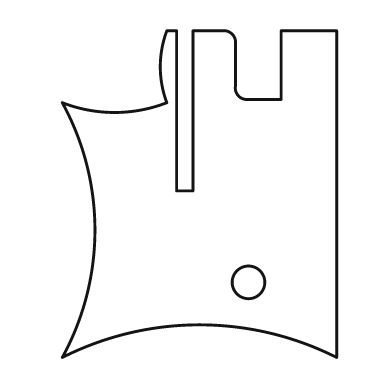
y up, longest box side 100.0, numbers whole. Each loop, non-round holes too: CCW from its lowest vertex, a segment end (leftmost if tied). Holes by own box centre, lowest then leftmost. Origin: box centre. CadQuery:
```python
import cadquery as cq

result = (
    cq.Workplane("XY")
    .moveTo(-42.0, -50.0)
    .threePointArc((0.0, -40.0), (42.0, -50.0))
    .lineTo(42.0, 50.0)
    .lineTo(25.0, 50.0)
    .lineTo(25.0, 29.0)
    .lineTo(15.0, 29.0)
    .threePointArc((12.0, 30.0), (11.0, 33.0))
    .lineTo(11.0, 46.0)
    .threePointArc((10.0, 49.0), (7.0, 50.0))
    .lineTo(-2.0, 50.0)
    .lineTo(-2.0, 1.0)
    .lineTo(-7.0, 1.0)
    .lineTo(-7.0, 50.0)
    .lineTo(-10.0, 50.0)
    .threePointArc((-12.0, 39.0), (-10.0, 28.0))
    .threePointArc((-26.0, 25.0), (-42.0, 28.0))
    .threePointArc((-32.0, -11.0), (-42.0, -50.0))
    .close()
    .moveTo(15.0, -27.0)
    .circle(5.0)
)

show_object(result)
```